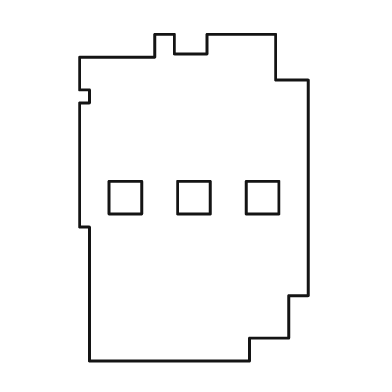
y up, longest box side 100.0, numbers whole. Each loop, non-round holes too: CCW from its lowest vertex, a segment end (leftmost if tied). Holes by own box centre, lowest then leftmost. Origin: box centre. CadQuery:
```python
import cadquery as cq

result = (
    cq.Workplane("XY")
    .moveTo(-32.0, -50.0)
    .lineTo(17.0, -50.0)
    .lineTo(17.0, -43.0)
    .lineTo(29.0, -43.0)
    .lineTo(29.0, -30.0)
    .lineTo(35.0, -30.0)
    .lineTo(35.0, 36.0)
    .lineTo(25.0, 36.0)
    .lineTo(25.0, 50.0)
    .lineTo(4.0, 50.0)
    .lineTo(4.0, 44.0)
    .lineTo(-6.0, 44.0)
    .lineTo(-6.0, 50.0)
    .lineTo(-12.0, 50.0)
    .lineTo(-12.0, 43.0)
    .lineTo(-35.0, 43.0)
    .lineTo(-35.0, 33.0)
    .lineTo(-32.0, 33.0)
    .lineTo(-32.0, 29.0)
    .lineTo(-35.0, 29.0)
    .lineTo(-35.0, -9.0)
    .lineTo(-32.0, -9.0)
    .close()
    .moveTo(-26.0, -5.0)
    .lineTo(-16.0, -5.0)
    .lineTo(-16.0, 5.0)
    .lineTo(-26.0, 5.0)
    .close()
    .moveTo(-5.0, -5.0)
    .lineTo(5.0, -5.0)
    .lineTo(5.0, 5.0)
    .lineTo(-5.0, 5.0)
    .close()
    .moveTo(16.0, -5.0)
    .lineTo(26.0, -5.0)
    .lineTo(26.0, 5.0)
    .lineTo(16.0, 5.0)
    .close()
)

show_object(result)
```